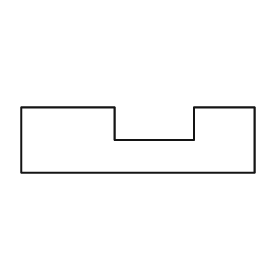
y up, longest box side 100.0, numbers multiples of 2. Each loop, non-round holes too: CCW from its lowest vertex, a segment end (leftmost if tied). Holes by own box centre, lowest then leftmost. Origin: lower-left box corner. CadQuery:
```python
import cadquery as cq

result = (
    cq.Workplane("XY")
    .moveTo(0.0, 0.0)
    .lineTo(100.0, 0.0)
    .lineTo(100.0, 28.0)
    .lineTo(74.0, 28.0)
    .lineTo(74.0, 14.0)
    .lineTo(40.0, 14.0)
    .lineTo(40.0, 28.0)
    .lineTo(0.0, 28.0)
    .close()
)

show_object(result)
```